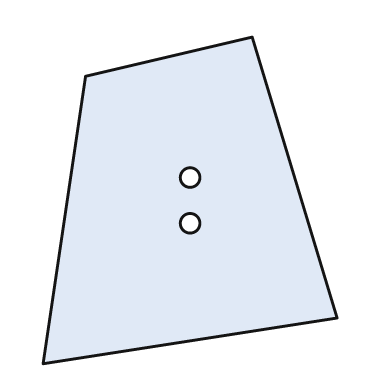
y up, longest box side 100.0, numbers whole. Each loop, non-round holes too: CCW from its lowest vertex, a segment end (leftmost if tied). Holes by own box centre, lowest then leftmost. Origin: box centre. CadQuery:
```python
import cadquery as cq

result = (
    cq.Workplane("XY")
    .moveTo(-45.0, -50.0)
    .lineTo(45.0, -36.0)
    .lineTo(19.0, 50.0)
    .lineTo(-32.0, 38.0)
    .close()
    .moveTo(0.0, -7.0)
    .circle(3.0)
    .moveTo(0.0, 7.0)
    .circle(3.0)
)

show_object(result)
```